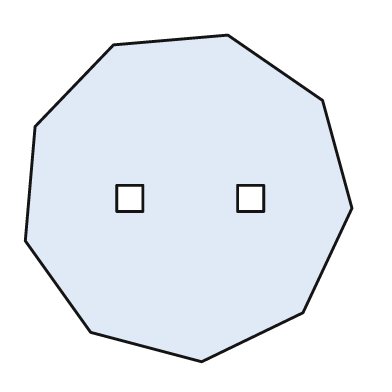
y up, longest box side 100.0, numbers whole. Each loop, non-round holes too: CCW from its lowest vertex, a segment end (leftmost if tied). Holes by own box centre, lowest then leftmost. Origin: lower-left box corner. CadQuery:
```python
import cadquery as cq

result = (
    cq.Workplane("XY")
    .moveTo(54.0, 0.0)
    .lineTo(85.0, 15.0)
    .lineTo(100.0, 47.0)
    .lineTo(91.0, 80.0)
    .lineTo(62.0, 100.0)
    .lineTo(27.0, 97.0)
    .lineTo(3.0, 72.0)
    .lineTo(0.0, 37.0)
    .lineTo(20.0, 9.0)
    .close()
    .moveTo(28.0, 46.0)
    .lineTo(36.0, 46.0)
    .lineTo(36.0, 54.0)
    .lineTo(28.0, 54.0)
    .close()
    .moveTo(65.0, 46.0)
    .lineTo(73.0, 46.0)
    .lineTo(73.0, 54.0)
    .lineTo(65.0, 54.0)
    .close()
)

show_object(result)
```